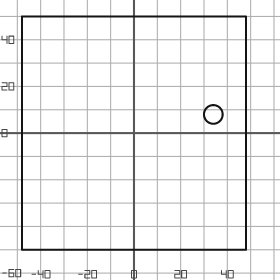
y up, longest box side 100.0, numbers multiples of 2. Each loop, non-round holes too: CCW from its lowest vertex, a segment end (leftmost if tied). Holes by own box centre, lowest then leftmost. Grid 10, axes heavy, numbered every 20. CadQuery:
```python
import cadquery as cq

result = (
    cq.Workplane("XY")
    .moveTo(-48.0, -50.0)
    .lineTo(48.0, -50.0)
    .lineTo(48.0, 50.0)
    .lineTo(-48.0, 50.0)
    .close()
    .moveTo(34.0, 8.0)
    .circle(4.0)
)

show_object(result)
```